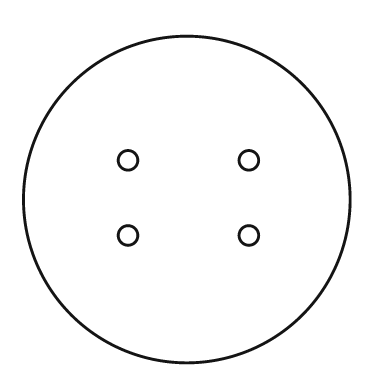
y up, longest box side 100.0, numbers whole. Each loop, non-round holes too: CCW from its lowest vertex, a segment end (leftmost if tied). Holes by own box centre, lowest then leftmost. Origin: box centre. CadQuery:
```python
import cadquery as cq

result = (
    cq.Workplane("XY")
    .moveTo(0.0, 0.0)
    .circle(50.0)
    .moveTo(-18.0, -11.0)
    .circle(3.0)
    .moveTo(19.0, -11.0)
    .circle(3.0)
    .moveTo(-18.0, 12.0)
    .circle(3.0)
    .moveTo(19.0, 12.0)
    .circle(3.0)
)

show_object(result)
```